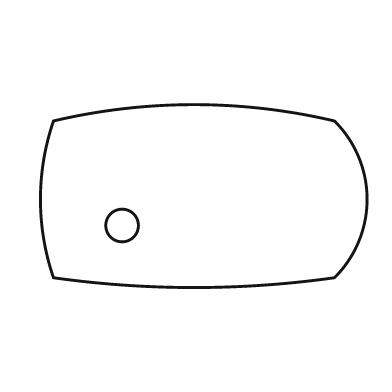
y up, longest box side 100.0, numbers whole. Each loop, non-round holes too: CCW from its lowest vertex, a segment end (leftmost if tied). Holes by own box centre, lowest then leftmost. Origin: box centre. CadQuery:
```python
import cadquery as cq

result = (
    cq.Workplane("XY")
    .moveTo(-46.0, -25.0)
    .threePointArc((-3.0, -28.0), (40.0, -25.0))
    .threePointArc((50.0, -1.0), (40.0, 23.0))
    .threePointArc((-3.0, 28.0), (-46.0, 23.0))
    .threePointArc((-50.0, -1.0), (-46.0, -25.0))
    .close()
    .moveTo(-25.0, -9.0)
    .circle(5.0)
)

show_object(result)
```